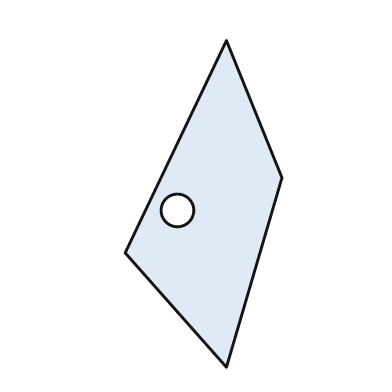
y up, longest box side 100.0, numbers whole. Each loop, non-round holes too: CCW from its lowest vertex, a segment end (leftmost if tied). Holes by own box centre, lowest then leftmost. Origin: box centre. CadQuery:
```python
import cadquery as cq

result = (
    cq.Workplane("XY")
    .moveTo(7.0, -50.0)
    .lineTo(24.0, 8.0)
    .lineTo(7.0, 50.0)
    .lineTo(-24.0, -15.0)
    .close()
    .moveTo(-8.0, -2.0)
    .circle(5.0)
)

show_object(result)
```